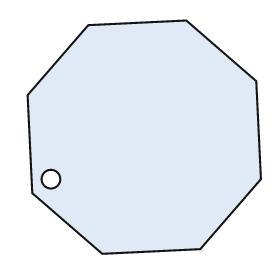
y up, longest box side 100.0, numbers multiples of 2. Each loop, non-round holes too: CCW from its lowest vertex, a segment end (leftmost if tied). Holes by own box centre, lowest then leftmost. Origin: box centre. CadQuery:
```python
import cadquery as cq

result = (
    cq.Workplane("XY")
    .moveTo(-18.0, -50.0)
    .lineTo(24.0, -48.0)
    .lineTo(50.0, -18.0)
    .lineTo(48.0, 24.0)
    .lineTo(18.0, 50.0)
    .lineTo(-24.0, 48.0)
    .lineTo(-50.0, 18.0)
    .lineTo(-48.0, -24.0)
    .close()
    .moveTo(-40.0, -18.0)
    .circle(4.0)
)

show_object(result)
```